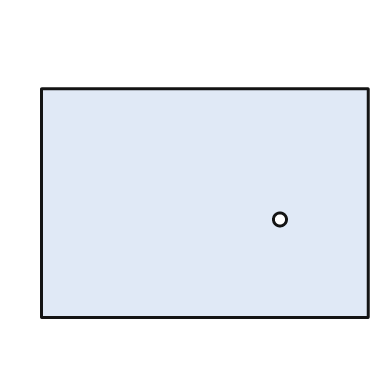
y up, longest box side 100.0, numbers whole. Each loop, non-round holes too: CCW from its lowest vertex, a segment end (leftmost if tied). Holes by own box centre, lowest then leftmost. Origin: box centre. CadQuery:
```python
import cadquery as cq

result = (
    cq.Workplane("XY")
    .moveTo(-50.0, -35.0)
    .lineTo(50.0, -35.0)
    .lineTo(50.0, 35.0)
    .lineTo(-50.0, 35.0)
    .close()
    .moveTo(23.0, -5.0)
    .circle(2.0)
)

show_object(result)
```